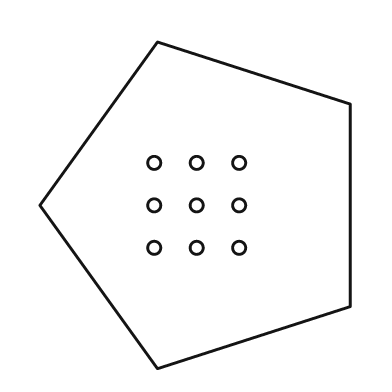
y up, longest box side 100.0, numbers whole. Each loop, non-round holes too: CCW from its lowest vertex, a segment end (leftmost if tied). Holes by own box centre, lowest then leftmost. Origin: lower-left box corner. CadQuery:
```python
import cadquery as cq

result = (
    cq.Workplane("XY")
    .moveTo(36.0, 0.0)
    .lineTo(95.0, 19.0)
    .lineTo(95.0, 81.0)
    .lineTo(36.0, 100.0)
    .lineTo(0.0, 50.0)
    .close()
    .moveTo(35.0, 37.0)
    .circle(2.0)
    .moveTo(48.0, 37.0)
    .circle(2.0)
    .moveTo(61.0, 37.0)
    .circle(2.0)
    .moveTo(35.0, 50.0)
    .circle(2.0)
    .moveTo(48.0, 50.0)
    .circle(2.0)
    .moveTo(61.0, 50.0)
    .circle(2.0)
    .moveTo(35.0, 63.0)
    .circle(2.0)
    .moveTo(48.0, 63.0)
    .circle(2.0)
    .moveTo(61.0, 63.0)
    .circle(2.0)
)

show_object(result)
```